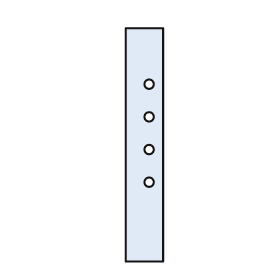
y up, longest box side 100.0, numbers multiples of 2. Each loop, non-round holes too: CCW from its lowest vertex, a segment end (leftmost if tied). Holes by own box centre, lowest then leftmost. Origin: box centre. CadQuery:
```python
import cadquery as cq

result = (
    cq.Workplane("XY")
    .moveTo(-8.0, -50.0)
    .lineTo(8.0, -50.0)
    .lineTo(8.0, 50.0)
    .lineTo(-8.0, 50.0)
    .close()
    .moveTo(2.0, -16.0)
    .circle(2.0)
    .moveTo(2.0, -2.0)
    .circle(2.0)
    .moveTo(2.0, 12.0)
    .circle(2.0)
    .moveTo(2.0, 26.0)
    .circle(2.0)
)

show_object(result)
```